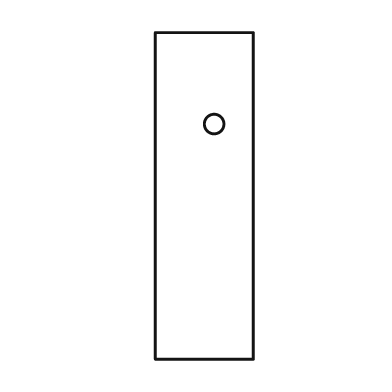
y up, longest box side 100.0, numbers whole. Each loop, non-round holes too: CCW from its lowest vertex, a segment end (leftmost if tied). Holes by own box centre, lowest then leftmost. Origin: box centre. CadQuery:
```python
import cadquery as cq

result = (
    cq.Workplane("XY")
    .moveTo(-15.0, -50.0)
    .lineTo(15.0, -50.0)
    .lineTo(15.0, 50.0)
    .lineTo(-15.0, 50.0)
    .close()
    .moveTo(3.0, 22.0)
    .circle(3.0)
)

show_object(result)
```